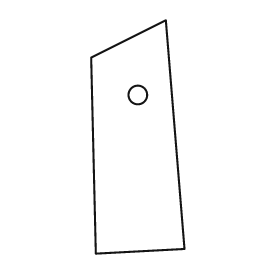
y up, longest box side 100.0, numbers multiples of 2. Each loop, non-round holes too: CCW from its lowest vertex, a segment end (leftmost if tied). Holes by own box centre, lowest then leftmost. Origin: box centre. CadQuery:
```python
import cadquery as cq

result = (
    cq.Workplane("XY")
    .moveTo(-18.0, -50.0)
    .lineTo(20.0, -48.0)
    .lineTo(12.0, 50.0)
    .lineTo(-20.0, 34.0)
    .close()
    .moveTo(0.0, 18.0)
    .circle(4.0)
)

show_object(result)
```